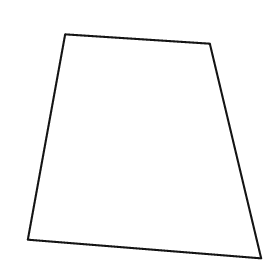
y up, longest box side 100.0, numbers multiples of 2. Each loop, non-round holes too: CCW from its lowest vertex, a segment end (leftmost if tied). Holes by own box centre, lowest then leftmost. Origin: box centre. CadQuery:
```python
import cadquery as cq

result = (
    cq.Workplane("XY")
    .moveTo(50.0, -48.0)
    .lineTo(28.0, 44.0)
    .lineTo(-34.0, 48.0)
    .lineTo(-50.0, -40.0)
    .close()
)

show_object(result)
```